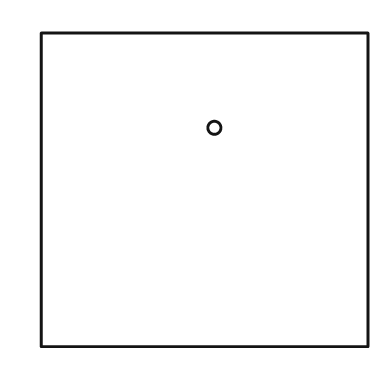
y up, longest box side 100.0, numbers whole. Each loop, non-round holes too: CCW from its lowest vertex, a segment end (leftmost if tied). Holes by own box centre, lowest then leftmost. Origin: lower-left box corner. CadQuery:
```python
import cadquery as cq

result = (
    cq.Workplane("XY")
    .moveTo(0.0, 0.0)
    .lineTo(100.0, 0.0)
    .lineTo(100.0, 96.0)
    .lineTo(0.0, 96.0)
    .close()
    .moveTo(53.0, 67.0)
    .circle(2.0)
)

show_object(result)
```